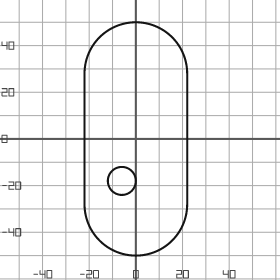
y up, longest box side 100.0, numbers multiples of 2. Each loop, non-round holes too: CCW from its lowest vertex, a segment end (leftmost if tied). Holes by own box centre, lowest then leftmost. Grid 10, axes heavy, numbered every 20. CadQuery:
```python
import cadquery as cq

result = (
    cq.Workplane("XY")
    .moveTo(-22.0, -28.0)
    .threePointArc((0.0, -50.0), (22.0, -28.0))
    .lineTo(22.0, 28.0)
    .threePointArc((0.0, 50.0), (-22.0, 28.0))
    .close()
    .moveTo(-6.0, -18.0)
    .circle(6.0)
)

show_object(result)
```